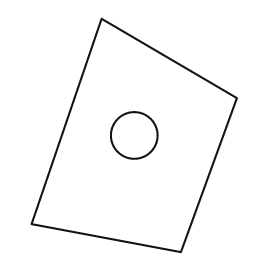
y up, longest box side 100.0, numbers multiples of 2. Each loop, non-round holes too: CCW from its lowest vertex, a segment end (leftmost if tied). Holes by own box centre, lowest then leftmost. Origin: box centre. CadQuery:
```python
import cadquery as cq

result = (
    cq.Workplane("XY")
    .moveTo(20.0, -50.0)
    .lineTo(44.0, 16.0)
    .lineTo(-14.0, 50.0)
    .lineTo(-44.0, -38.0)
    .close()
    .moveTo(0.0, 0.0)
    .circle(10.0)
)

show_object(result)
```